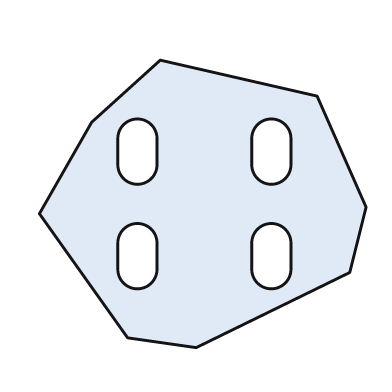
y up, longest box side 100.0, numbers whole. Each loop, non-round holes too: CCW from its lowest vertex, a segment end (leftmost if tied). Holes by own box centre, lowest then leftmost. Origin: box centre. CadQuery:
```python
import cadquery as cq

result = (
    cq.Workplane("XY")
    .moveTo(-2.0, -44.0)
    .lineTo(45.0, -21.0)
    .lineTo(50.0, -1.0)
    .lineTo(35.0, 33.0)
    .lineTo(-13.0, 44.0)
    .lineTo(-34.0, 25.0)
    .lineTo(-50.0, -3.0)
    .lineTo(-23.0, -41.0)
    .close()
    .moveTo(-26.0, -20.0)
    .threePointArc((-20.0, -26.0), (-14.0, -20.0))
    .lineTo(-14.0, -12.0)
    .threePointArc((-20.0, -6.0), (-26.0, -12.0))
    .close()
    .moveTo(15.0, -20.0)
    .threePointArc((21.0, -26.0), (27.0, -20.0))
    .lineTo(27.0, -12.0)
    .threePointArc((21.0, -6.0), (15.0, -12.0))
    .close()
    .moveTo(-26.0, 12.0)
    .threePointArc((-20.0, 6.0), (-14.0, 12.0))
    .lineTo(-14.0, 20.0)
    .threePointArc((-20.0, 26.0), (-26.0, 20.0))
    .close()
    .moveTo(15.0, 12.0)
    .threePointArc((21.0, 6.0), (27.0, 12.0))
    .lineTo(27.0, 20.0)
    .threePointArc((21.0, 26.0), (15.0, 20.0))
    .close()
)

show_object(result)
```